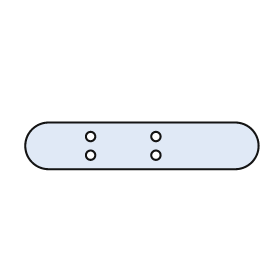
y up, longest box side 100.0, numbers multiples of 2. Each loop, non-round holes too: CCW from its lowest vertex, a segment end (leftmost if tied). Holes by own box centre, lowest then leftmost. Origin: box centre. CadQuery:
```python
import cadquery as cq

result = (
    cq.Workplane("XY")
    .moveTo(-40.0, -10.0)
    .lineTo(40.0, -10.0)
    .threePointArc((50.0, 0.0), (40.0, 10.0))
    .lineTo(-40.0, 10.0)
    .threePointArc((-50.0, 0.0), (-40.0, -10.0))
    .close()
    .moveTo(-22.0, -4.0)
    .circle(2.0)
    .moveTo(6.0, -4.0)
    .circle(2.0)
    .moveTo(-22.0, 4.0)
    .circle(2.0)
    .moveTo(6.0, 4.0)
    .circle(2.0)
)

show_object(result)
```